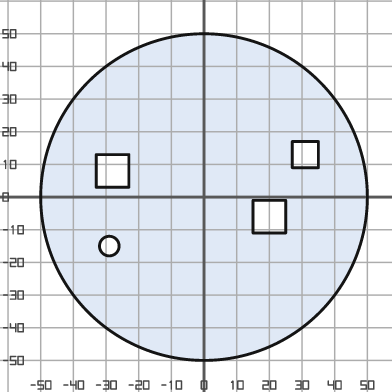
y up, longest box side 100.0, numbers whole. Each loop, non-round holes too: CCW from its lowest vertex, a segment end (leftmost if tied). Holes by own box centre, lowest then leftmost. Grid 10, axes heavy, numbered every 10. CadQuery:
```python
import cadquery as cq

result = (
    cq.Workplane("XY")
    .moveTo(0.0, 0.0)
    .circle(50.0)
    .moveTo(-29.0, -15.0)
    .circle(3.0)
    .moveTo(15.0, -11.0)
    .lineTo(25.0, -11.0)
    .lineTo(25.0, -1.0)
    .lineTo(15.0, -1.0)
    .close()
    .moveTo(-33.0, 3.0)
    .lineTo(-23.0, 3.0)
    .lineTo(-23.0, 13.0)
    .lineTo(-33.0, 13.0)
    .close()
    .moveTo(27.0, 9.0)
    .lineTo(35.0, 9.0)
    .lineTo(35.0, 17.0)
    .lineTo(27.0, 17.0)
    .close()
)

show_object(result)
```